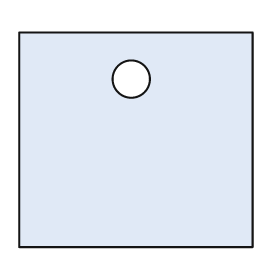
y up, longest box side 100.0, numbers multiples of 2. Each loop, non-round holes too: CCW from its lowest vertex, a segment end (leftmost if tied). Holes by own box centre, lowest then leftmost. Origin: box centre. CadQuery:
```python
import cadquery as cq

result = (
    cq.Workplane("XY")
    .moveTo(-50.0, -46.0)
    .lineTo(50.0, -46.0)
    .lineTo(50.0, 46.0)
    .lineTo(-50.0, 46.0)
    .close()
    .moveTo(-2.0, 26.0)
    .circle(8.0)
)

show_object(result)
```